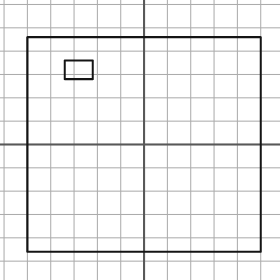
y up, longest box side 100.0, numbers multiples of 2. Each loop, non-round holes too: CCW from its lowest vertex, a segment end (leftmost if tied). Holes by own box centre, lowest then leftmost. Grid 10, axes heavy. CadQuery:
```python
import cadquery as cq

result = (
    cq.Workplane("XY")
    .moveTo(-50.0, -46.0)
    .lineTo(50.0, -46.0)
    .lineTo(50.0, 46.0)
    .lineTo(-50.0, 46.0)
    .close()
    .moveTo(-34.0, 28.0)
    .lineTo(-22.0, 28.0)
    .lineTo(-22.0, 36.0)
    .lineTo(-34.0, 36.0)
    .close()
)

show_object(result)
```